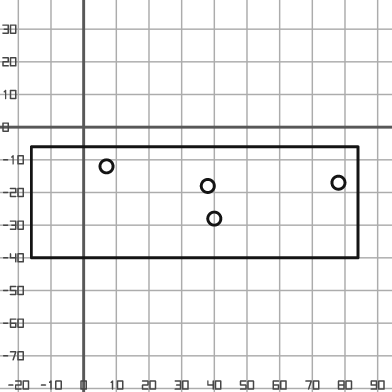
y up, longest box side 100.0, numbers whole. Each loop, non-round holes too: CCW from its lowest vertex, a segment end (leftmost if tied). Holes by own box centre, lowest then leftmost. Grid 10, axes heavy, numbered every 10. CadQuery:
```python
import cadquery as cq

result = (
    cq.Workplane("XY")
    .moveTo(-16.0, -40.0)
    .lineTo(84.0, -40.0)
    .lineTo(84.0, -6.0)
    .lineTo(-16.0, -6.0)
    .close()
    .moveTo(40.0, -28.0)
    .circle(2.0)
    .moveTo(38.0, -18.0)
    .circle(2.0)
    .moveTo(78.0, -17.0)
    .circle(2.0)
    .moveTo(7.0, -12.0)
    .circle(2.0)
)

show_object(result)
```